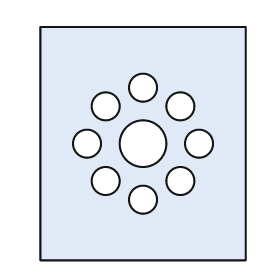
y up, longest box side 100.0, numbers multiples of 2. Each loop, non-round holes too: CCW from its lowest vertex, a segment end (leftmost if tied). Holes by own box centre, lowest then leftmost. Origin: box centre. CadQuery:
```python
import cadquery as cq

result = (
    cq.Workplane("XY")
    .moveTo(-44.0, -50.0)
    .lineTo(44.0, -50.0)
    .lineTo(44.0, 50.0)
    .lineTo(-44.0, 50.0)
    .close()
    .moveTo(0.0, -24.0)
    .circle(6.0)
    .moveTo(-16.0, -16.0)
    .circle(6.0)
    .moveTo(16.0, -16.0)
    .circle(6.0)
    .moveTo(-24.0, 0.0)
    .circle(6.0)
    .moveTo(0.0, 0.0)
    .circle(10.0)
    .moveTo(24.0, 0.0)
    .circle(6.0)
    .moveTo(-16.0, 16.0)
    .circle(6.0)
    .moveTo(16.0, 16.0)
    .circle(6.0)
    .moveTo(0.0, 24.0)
    .circle(6.0)
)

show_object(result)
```